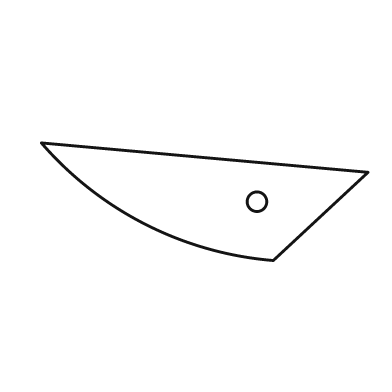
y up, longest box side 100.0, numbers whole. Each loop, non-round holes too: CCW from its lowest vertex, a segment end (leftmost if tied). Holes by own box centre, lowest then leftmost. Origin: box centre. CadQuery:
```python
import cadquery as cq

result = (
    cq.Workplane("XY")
    .moveTo(21.0, -18.0)
    .lineTo(50.0, 9.0)
    .lineTo(-50.0, 18.0)
    .threePointArc((-18.0, -7.0), (21.0, -18.0))
    .close()
    .moveTo(16.0, 0.0)
    .circle(3.0)
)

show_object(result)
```